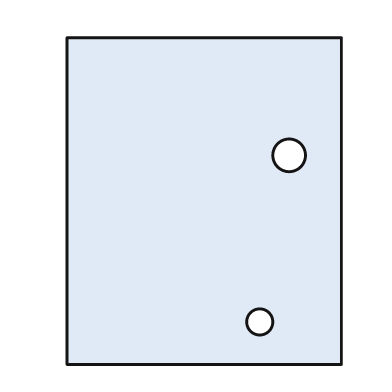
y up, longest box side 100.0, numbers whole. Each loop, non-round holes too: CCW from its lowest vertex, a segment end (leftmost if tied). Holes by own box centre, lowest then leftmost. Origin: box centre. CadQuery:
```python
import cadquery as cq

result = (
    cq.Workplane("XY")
    .moveTo(-42.0, -50.0)
    .lineTo(42.0, -50.0)
    .lineTo(42.0, 50.0)
    .lineTo(-42.0, 50.0)
    .close()
    .moveTo(17.0, -37.0)
    .circle(4.0)
    .moveTo(26.0, 14.0)
    .circle(5.0)
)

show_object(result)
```